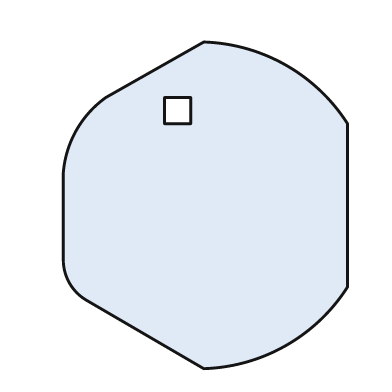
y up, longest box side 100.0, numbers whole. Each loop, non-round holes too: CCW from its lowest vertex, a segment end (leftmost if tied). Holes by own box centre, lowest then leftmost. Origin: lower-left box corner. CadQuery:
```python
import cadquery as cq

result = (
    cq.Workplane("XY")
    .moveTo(43.0, 0.0)
    .threePointArc((68.0, 7.0), (87.0, 25.0))
    .lineTo(87.0, 75.0)
    .threePointArc((68.0, 93.0), (43.0, 100.0))
    .lineTo(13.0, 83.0)
    .threePointArc((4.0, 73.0), (0.0, 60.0))
    .lineTo(0.0, 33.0)
    .threePointArc((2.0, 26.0), (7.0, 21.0))
    .close()
    .moveTo(31.0, 75.0)
    .lineTo(39.0, 75.0)
    .lineTo(39.0, 83.0)
    .lineTo(31.0, 83.0)
    .close()
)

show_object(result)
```